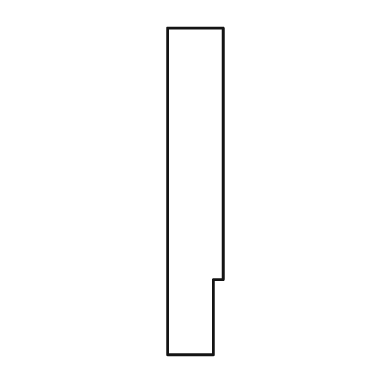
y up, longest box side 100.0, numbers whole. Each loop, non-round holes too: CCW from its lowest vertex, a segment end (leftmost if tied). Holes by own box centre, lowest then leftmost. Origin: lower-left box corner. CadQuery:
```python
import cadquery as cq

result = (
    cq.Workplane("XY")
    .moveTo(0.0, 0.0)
    .lineTo(14.0, 0.0)
    .lineTo(14.0, 23.0)
    .lineTo(17.0, 23.0)
    .lineTo(17.0, 100.0)
    .lineTo(0.0, 100.0)
    .close()
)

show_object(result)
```